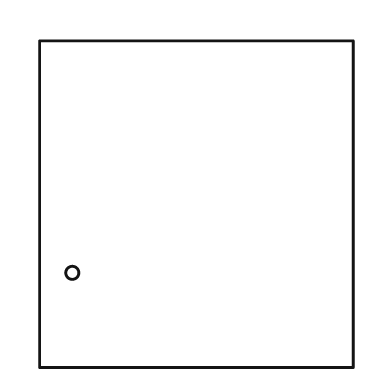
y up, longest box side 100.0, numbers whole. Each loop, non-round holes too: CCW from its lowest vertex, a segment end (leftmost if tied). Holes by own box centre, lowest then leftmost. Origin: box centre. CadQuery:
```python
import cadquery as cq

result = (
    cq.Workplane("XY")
    .moveTo(-48.0, -50.0)
    .lineTo(48.0, -50.0)
    .lineTo(48.0, 50.0)
    .lineTo(-48.0, 50.0)
    .close()
    .moveTo(-38.0, -21.0)
    .circle(2.0)
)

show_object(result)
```